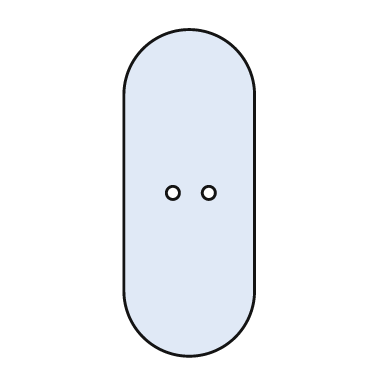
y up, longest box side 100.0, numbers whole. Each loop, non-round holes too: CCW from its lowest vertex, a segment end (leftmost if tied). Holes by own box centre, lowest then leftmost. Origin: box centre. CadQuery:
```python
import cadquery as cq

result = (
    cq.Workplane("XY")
    .moveTo(-20.0, -30.0)
    .threePointArc((0.0, -50.0), (20.0, -30.0))
    .lineTo(20.0, 30.0)
    .threePointArc((0.0, 50.0), (-20.0, 30.0))
    .close()
    .moveTo(-5.0, 0.0)
    .circle(2.0)
    .moveTo(6.0, 0.0)
    .circle(2.0)
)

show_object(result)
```